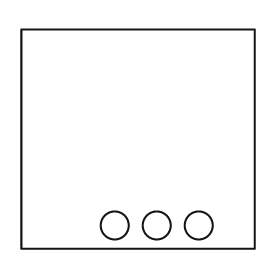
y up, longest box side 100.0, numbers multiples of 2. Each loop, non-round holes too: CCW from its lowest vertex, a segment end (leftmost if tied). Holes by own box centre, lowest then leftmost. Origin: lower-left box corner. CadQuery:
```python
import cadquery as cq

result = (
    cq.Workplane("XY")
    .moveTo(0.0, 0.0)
    .lineTo(100.0, 0.0)
    .lineTo(100.0, 94.0)
    .lineTo(0.0, 94.0)
    .close()
    .moveTo(40.0, 10.0)
    .circle(6.0)
    .moveTo(58.0, 10.0)
    .circle(6.0)
    .moveTo(76.0, 10.0)
    .circle(6.0)
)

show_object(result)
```